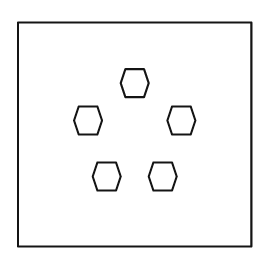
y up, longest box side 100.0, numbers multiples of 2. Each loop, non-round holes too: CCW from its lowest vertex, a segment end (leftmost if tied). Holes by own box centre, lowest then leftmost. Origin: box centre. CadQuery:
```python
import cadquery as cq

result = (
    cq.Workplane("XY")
    .moveTo(-50.0, -48.0)
    .lineTo(50.0, -48.0)
    .lineTo(50.0, 48.0)
    .lineTo(-50.0, 48.0)
    .close()
    .moveTo(-16.0, -24.0)
    .lineTo(-8.0, -24.0)
    .lineTo(-6.0, -18.0)
    .lineTo(-8.0, -12.0)
    .lineTo(-16.0, -12.0)
    .lineTo(-18.0, -18.0)
    .close()
    .moveTo(8.0, -24.0)
    .lineTo(16.0, -24.0)
    .lineTo(18.0, -18.0)
    .lineTo(16.0, -12.0)
    .lineTo(8.0, -12.0)
    .lineTo(6.0, -18.0)
    .close()
    .moveTo(-24.0, 0.0)
    .lineTo(-16.0, 0.0)
    .lineTo(-14.0, 6.0)
    .lineTo(-16.0, 12.0)
    .lineTo(-24.0, 12.0)
    .lineTo(-26.0, 6.0)
    .close()
    .moveTo(16.0, 0.0)
    .lineTo(24.0, 0.0)
    .lineTo(26.0, 6.0)
    .lineTo(24.0, 12.0)
    .lineTo(16.0, 12.0)
    .lineTo(14.0, 6.0)
    .close()
    .moveTo(-4.0, 16.0)
    .lineTo(4.0, 16.0)
    .lineTo(6.0, 22.0)
    .lineTo(4.0, 28.0)
    .lineTo(-4.0, 28.0)
    .lineTo(-6.0, 22.0)
    .close()
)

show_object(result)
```